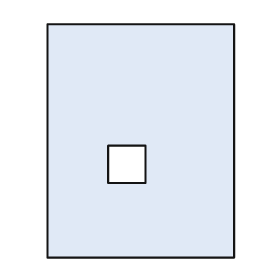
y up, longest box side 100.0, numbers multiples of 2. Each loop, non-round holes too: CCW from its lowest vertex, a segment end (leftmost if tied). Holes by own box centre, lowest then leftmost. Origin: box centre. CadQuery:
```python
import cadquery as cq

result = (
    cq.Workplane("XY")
    .moveTo(-40.0, -50.0)
    .lineTo(40.0, -50.0)
    .lineTo(40.0, 50.0)
    .lineTo(-40.0, 50.0)
    .close()
    .moveTo(-14.0, -18.0)
    .lineTo(2.0, -18.0)
    .lineTo(2.0, -2.0)
    .lineTo(-14.0, -2.0)
    .close()
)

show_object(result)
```